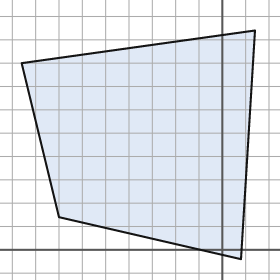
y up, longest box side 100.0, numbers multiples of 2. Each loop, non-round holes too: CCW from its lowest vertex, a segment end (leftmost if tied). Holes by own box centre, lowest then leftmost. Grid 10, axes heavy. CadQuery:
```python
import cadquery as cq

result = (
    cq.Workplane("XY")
    .moveTo(8.0, -4.0)
    .lineTo(14.0, 94.0)
    .lineTo(-86.0, 80.0)
    .lineTo(-70.0, 14.0)
    .close()
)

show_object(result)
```